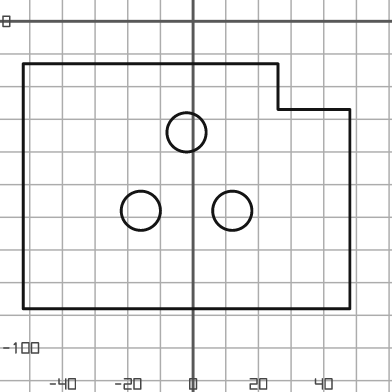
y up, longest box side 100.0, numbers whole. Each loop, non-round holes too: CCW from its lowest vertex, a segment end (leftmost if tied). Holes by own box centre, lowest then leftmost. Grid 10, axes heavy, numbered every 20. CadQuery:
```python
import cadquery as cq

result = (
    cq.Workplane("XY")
    .moveTo(-52.0, -88.0)
    .lineTo(48.0, -88.0)
    .lineTo(48.0, -27.0)
    .lineTo(26.0, -27.0)
    .lineTo(26.0, -13.0)
    .lineTo(-52.0, -13.0)
    .close()
    .moveTo(-16.0, -58.0)
    .circle(6.0)
    .moveTo(12.0, -58.0)
    .circle(6.0)
    .moveTo(-2.0, -34.0)
    .circle(6.0)
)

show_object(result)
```